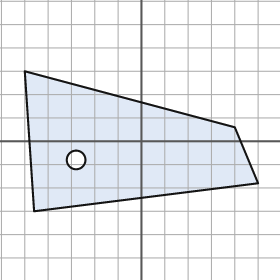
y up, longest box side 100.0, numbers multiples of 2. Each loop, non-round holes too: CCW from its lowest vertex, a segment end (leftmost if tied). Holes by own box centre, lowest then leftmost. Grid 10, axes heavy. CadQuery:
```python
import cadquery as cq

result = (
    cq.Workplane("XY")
    .moveTo(-46.0, -30.0)
    .lineTo(50.0, -18.0)
    .lineTo(40.0, 6.0)
    .lineTo(-50.0, 30.0)
    .close()
    .moveTo(-28.0, -8.0)
    .circle(4.0)
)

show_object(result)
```